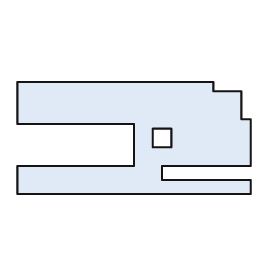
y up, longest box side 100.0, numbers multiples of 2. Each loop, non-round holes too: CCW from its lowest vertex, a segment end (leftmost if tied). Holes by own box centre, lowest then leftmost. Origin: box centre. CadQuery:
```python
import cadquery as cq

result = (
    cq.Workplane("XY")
    .moveTo(-50.0, -24.0)
    .lineTo(50.0, -24.0)
    .lineTo(50.0, -18.0)
    .lineTo(12.0, -18.0)
    .lineTo(12.0, -12.0)
    .lineTo(50.0, -12.0)
    .lineTo(50.0, 8.0)
    .lineTo(46.0, 8.0)
    .lineTo(46.0, 20.0)
    .lineTo(34.0, 20.0)
    .lineTo(34.0, 24.0)
    .lineTo(-50.0, 24.0)
    .lineTo(-50.0, 6.0)
    .lineTo(0.0, 6.0)
    .lineTo(0.0, -12.0)
    .lineTo(-50.0, -12.0)
    .close()
    .moveTo(8.0, -4.0)
    .lineTo(16.0, -4.0)
    .lineTo(16.0, 4.0)
    .lineTo(8.0, 4.0)
    .close()
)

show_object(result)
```